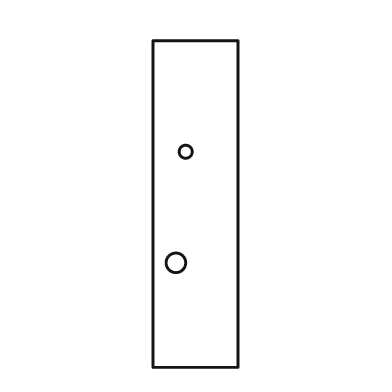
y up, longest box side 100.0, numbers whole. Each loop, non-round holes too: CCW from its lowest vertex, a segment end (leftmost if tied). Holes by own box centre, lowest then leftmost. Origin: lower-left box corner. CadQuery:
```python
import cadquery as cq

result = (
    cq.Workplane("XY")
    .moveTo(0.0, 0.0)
    .lineTo(26.0, 0.0)
    .lineTo(26.0, 100.0)
    .lineTo(0.0, 100.0)
    .close()
    .moveTo(7.0, 32.0)
    .circle(3.0)
    .moveTo(10.0, 66.0)
    .circle(2.0)
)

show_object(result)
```